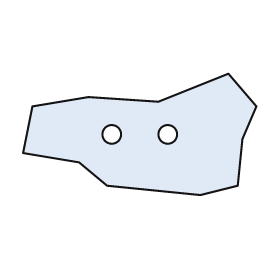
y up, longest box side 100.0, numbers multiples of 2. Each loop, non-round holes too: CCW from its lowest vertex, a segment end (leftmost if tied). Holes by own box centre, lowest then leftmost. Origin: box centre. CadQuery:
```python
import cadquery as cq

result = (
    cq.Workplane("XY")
    .moveTo(26.0, -26.0)
    .lineTo(42.0, -22.0)
    .lineTo(44.0, -2.0)
    .lineTo(50.0, 12.0)
    .lineTo(38.0, 26.0)
    .lineTo(8.0, 14.0)
    .lineTo(-22.0, 16.0)
    .lineTo(-46.0, 12.0)
    .lineTo(-50.0, -8.0)
    .lineTo(-26.0, -12.0)
    .lineTo(-14.0, -22.0)
    .close()
    .moveTo(-12.0, 0.0)
    .circle(4.0)
    .moveTo(12.0, 0.0)
    .circle(4.0)
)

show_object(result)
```